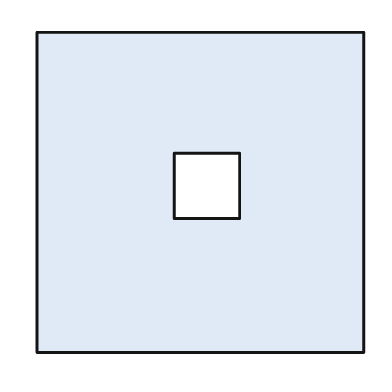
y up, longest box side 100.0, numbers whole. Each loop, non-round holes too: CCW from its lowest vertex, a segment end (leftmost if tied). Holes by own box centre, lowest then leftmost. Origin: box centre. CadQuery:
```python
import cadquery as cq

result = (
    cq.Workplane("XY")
    .moveTo(-50.0, -49.0)
    .lineTo(50.0, -49.0)
    .lineTo(50.0, 49.0)
    .lineTo(-50.0, 49.0)
    .close()
    .moveTo(-8.0, -8.0)
    .lineTo(12.0, -8.0)
    .lineTo(12.0, 12.0)
    .lineTo(-8.0, 12.0)
    .close()
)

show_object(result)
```